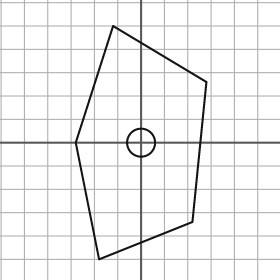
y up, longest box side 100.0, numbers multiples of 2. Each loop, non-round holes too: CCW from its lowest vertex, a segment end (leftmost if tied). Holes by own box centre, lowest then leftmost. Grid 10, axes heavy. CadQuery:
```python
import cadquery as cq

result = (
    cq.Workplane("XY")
    .moveTo(-18.0, -50.0)
    .lineTo(22.0, -34.0)
    .lineTo(28.0, 26.0)
    .lineTo(-12.0, 50.0)
    .lineTo(-28.0, 0.0)
    .close()
    .moveTo(0.0, 0.0)
    .circle(6.0)
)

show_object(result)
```